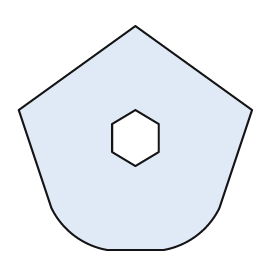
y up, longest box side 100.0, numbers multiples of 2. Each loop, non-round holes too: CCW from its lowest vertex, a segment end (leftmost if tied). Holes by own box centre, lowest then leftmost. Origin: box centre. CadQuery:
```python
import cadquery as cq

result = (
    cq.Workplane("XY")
    .moveTo(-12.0, -48.0)
    .lineTo(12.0, -48.0)
    .threePointArc((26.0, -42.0), (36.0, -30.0))
    .lineTo(50.0, 12.0)
    .lineTo(0.0, 48.0)
    .lineTo(-50.0, 12.0)
    .lineTo(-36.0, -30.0)
    .threePointArc((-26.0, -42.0), (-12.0, -48.0))
    .close()
    .moveTo(0.0, -12.0)
    .lineTo(10.0, -6.0)
    .lineTo(10.0, 6.0)
    .lineTo(0.0, 12.0)
    .lineTo(-10.0, 6.0)
    .lineTo(-10.0, -6.0)
    .close()
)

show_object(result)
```